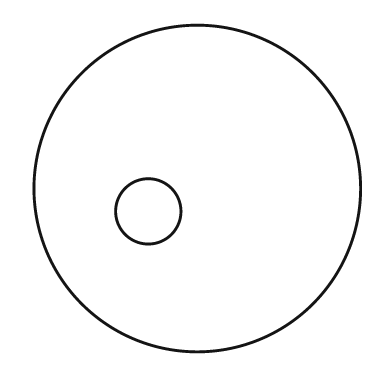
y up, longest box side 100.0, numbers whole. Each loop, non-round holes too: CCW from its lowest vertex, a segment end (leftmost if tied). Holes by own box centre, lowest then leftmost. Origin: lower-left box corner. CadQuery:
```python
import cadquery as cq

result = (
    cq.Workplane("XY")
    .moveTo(50.0, 50.0)
    .circle(50.0)
    .moveTo(35.0, 43.0)
    .circle(10.0)
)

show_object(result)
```